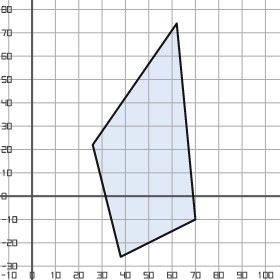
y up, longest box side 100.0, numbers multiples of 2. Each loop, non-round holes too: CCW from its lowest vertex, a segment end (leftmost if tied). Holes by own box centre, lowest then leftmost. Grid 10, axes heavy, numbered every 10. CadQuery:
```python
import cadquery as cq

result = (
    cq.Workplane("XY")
    .moveTo(38.0, -26.0)
    .lineTo(70.0, -10.0)
    .lineTo(62.0, 74.0)
    .lineTo(26.0, 22.0)
    .close()
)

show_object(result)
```